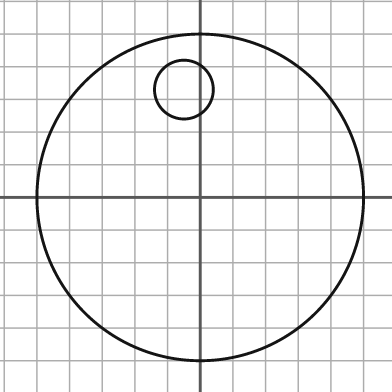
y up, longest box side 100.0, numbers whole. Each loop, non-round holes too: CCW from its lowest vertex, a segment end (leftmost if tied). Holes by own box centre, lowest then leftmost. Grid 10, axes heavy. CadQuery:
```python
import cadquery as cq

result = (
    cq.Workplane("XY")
    .moveTo(0.0, 0.0)
    .circle(50.0)
    .moveTo(-5.0, 33.0)
    .circle(9.0)
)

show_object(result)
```